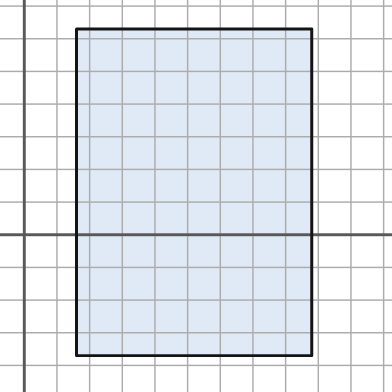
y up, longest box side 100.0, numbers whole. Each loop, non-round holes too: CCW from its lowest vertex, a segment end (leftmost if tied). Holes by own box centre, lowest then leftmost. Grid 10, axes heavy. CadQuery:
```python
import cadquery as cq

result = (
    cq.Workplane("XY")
    .moveTo(16.0, -37.0)
    .lineTo(88.0, -37.0)
    .lineTo(88.0, 63.0)
    .lineTo(16.0, 63.0)
    .close()
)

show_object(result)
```